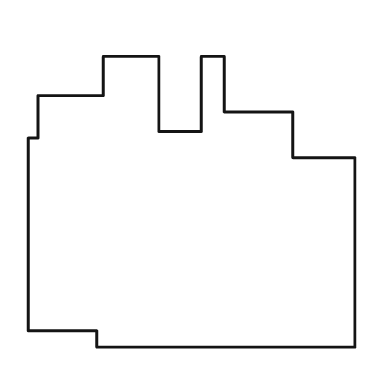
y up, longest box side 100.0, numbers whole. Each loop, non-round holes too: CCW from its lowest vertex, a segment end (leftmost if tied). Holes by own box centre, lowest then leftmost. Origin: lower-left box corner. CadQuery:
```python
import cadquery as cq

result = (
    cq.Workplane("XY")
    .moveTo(21.0, 0.0)
    .lineTo(100.0, 0.0)
    .lineTo(100.0, 58.0)
    .lineTo(81.0, 58.0)
    .lineTo(81.0, 72.0)
    .lineTo(60.0, 72.0)
    .lineTo(60.0, 89.0)
    .lineTo(53.0, 89.0)
    .lineTo(53.0, 66.0)
    .lineTo(40.0, 66.0)
    .lineTo(40.0, 89.0)
    .lineTo(23.0, 89.0)
    .lineTo(23.0, 77.0)
    .lineTo(3.0, 77.0)
    .lineTo(3.0, 64.0)
    .lineTo(0.0, 64.0)
    .lineTo(0.0, 5.0)
    .lineTo(21.0, 5.0)
    .close()
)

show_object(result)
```